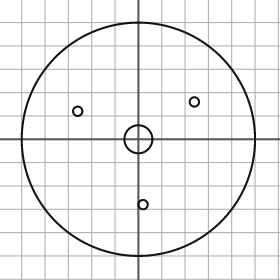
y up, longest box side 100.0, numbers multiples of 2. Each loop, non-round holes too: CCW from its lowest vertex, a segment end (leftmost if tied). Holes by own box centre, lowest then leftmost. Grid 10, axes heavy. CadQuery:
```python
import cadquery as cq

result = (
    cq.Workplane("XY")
    .moveTo(0.0, 0.0)
    .circle(50.0)
    .moveTo(2.0, -28.0)
    .circle(2.0)
    .moveTo(0.0, 0.0)
    .circle(6.0)
    .moveTo(-26.0, 12.0)
    .circle(2.0)
    .moveTo(24.0, 16.0)
    .circle(2.0)
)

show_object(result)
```